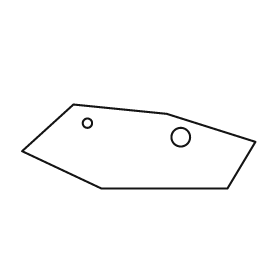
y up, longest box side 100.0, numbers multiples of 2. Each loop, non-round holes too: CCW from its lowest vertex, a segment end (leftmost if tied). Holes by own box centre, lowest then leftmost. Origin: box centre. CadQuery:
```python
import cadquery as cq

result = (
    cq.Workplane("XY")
    .moveTo(-16.0, -18.0)
    .lineTo(38.0, -18.0)
    .lineTo(50.0, 2.0)
    .lineTo(12.0, 14.0)
    .lineTo(-28.0, 18.0)
    .lineTo(-50.0, -2.0)
    .close()
    .moveTo(18.0, 4.0)
    .circle(4.0)
    .moveTo(-22.0, 10.0)
    .circle(2.0)
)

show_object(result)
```